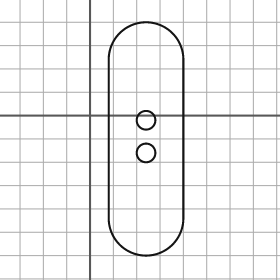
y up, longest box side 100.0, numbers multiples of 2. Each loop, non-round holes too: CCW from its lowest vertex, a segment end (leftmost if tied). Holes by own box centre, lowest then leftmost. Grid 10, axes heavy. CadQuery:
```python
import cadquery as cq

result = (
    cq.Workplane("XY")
    .moveTo(8.0, -44.0)
    .threePointArc((24.0, -60.0), (40.0, -44.0))
    .lineTo(40.0, 24.0)
    .threePointArc((24.0, 40.0), (8.0, 24.0))
    .close()
    .moveTo(24.0, -16.0)
    .circle(4.0)
    .moveTo(24.0, -2.0)
    .circle(4.0)
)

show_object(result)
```